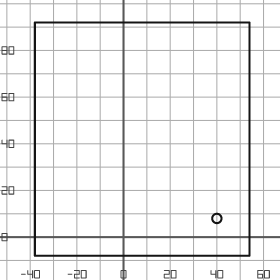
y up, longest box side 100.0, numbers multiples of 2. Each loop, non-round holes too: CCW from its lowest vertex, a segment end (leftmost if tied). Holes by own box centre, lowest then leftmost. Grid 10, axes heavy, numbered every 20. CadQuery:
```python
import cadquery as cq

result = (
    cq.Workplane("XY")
    .moveTo(-38.0, -8.0)
    .lineTo(54.0, -8.0)
    .lineTo(54.0, 92.0)
    .lineTo(-38.0, 92.0)
    .close()
    .moveTo(40.0, 8.0)
    .circle(2.0)
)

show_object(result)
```